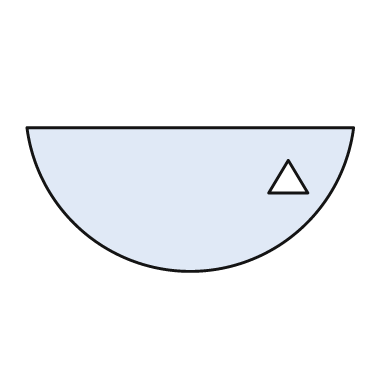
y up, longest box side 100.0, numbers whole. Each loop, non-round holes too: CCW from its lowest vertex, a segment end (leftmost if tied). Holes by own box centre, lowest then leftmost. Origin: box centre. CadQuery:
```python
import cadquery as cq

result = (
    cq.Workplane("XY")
    .moveTo(-50.0, 22.0)
    .threePointArc((0.0, -22.0), (50.0, 22.0))
    .close()
    .moveTo(24.0, 2.0)
    .lineTo(36.0, 2.0)
    .lineTo(30.0, 12.0)
    .close()
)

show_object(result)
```